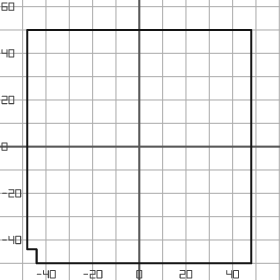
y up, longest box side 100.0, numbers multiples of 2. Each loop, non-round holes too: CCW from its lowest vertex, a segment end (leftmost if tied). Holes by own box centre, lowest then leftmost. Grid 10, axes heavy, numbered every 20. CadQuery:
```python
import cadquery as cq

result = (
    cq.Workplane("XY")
    .moveTo(-44.0, -50.0)
    .lineTo(48.0, -50.0)
    .lineTo(48.0, 50.0)
    .lineTo(-48.0, 50.0)
    .lineTo(-48.0, -44.0)
    .lineTo(-44.0, -44.0)
    .close()
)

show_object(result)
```